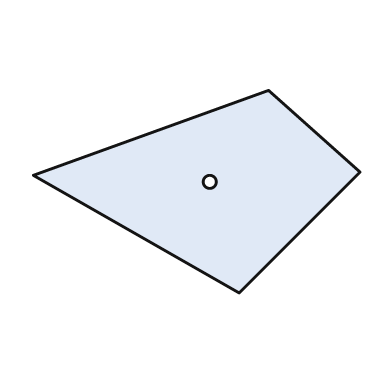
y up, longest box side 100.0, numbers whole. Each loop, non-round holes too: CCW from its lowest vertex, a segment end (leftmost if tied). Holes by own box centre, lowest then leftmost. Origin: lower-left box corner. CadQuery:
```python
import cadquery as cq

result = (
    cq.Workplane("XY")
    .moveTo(63.0, 0.0)
    .lineTo(100.0, 37.0)
    .lineTo(72.0, 62.0)
    .lineTo(0.0, 36.0)
    .close()
    .moveTo(54.0, 34.0)
    .circle(2.0)
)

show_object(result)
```